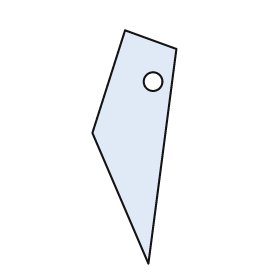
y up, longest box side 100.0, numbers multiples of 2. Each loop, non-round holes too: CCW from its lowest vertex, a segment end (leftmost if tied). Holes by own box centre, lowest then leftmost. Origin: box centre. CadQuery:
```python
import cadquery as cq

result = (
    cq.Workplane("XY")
    .moveTo(6.0, -50.0)
    .lineTo(18.0, 42.0)
    .lineTo(-4.0, 50.0)
    .lineTo(-18.0, 6.0)
    .close()
    .moveTo(8.0, 28.0)
    .circle(4.0)
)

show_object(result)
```